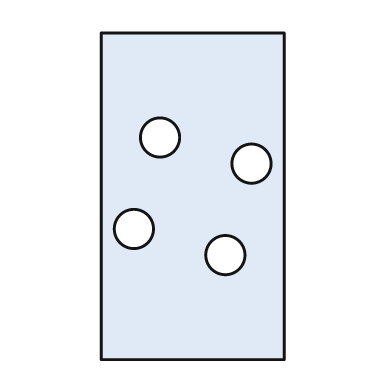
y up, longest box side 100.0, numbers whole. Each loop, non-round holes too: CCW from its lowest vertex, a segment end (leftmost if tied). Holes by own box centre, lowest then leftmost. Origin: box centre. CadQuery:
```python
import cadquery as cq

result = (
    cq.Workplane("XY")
    .moveTo(-28.0, -50.0)
    .lineTo(28.0, -50.0)
    .lineTo(28.0, 50.0)
    .lineTo(-28.0, 50.0)
    .close()
    .moveTo(10.0, -18.0)
    .circle(6.0)
    .moveTo(-18.0, -10.0)
    .circle(6.0)
    .moveTo(18.0, 10.0)
    .circle(6.0)
    .moveTo(-10.0, 18.0)
    .circle(6.0)
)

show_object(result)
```